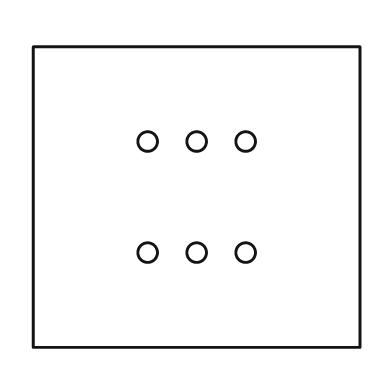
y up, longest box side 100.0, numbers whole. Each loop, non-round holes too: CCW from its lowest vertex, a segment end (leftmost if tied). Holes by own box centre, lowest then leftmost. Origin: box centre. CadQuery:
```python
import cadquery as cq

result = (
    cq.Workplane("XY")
    .moveTo(-50.0, -46.0)
    .lineTo(50.0, -46.0)
    .lineTo(50.0, 46.0)
    .lineTo(-50.0, 46.0)
    .close()
    .moveTo(-15.0, -17.0)
    .circle(3.0)
    .moveTo(0.0, -17.0)
    .circle(3.0)
    .moveTo(15.0, -17.0)
    .circle(3.0)
    .moveTo(-15.0, 17.0)
    .circle(3.0)
    .moveTo(0.0, 17.0)
    .circle(3.0)
    .moveTo(15.0, 17.0)
    .circle(3.0)
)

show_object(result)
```